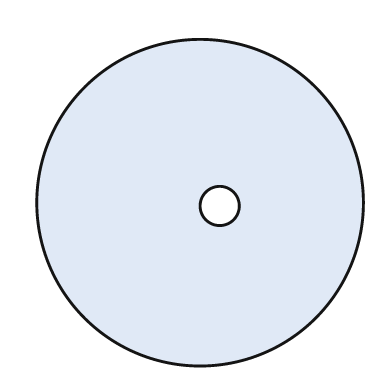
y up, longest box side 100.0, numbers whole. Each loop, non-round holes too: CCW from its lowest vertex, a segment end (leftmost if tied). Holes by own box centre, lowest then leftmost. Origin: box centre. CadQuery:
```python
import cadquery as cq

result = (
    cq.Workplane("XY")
    .moveTo(0.0, 0.0)
    .circle(50.0)
    .moveTo(6.0, -1.0)
    .circle(6.0)
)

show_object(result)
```